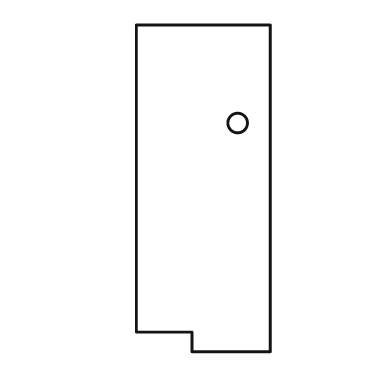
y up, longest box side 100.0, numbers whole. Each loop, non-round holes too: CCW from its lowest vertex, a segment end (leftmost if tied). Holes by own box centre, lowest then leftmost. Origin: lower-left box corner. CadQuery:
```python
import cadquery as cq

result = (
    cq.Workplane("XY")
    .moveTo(17.0, 0.0)
    .lineTo(41.0, 0.0)
    .lineTo(41.0, 100.0)
    .lineTo(0.0, 100.0)
    .lineTo(0.0, 6.0)
    .lineTo(17.0, 6.0)
    .close()
    .moveTo(31.0, 70.0)
    .circle(3.0)
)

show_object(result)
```